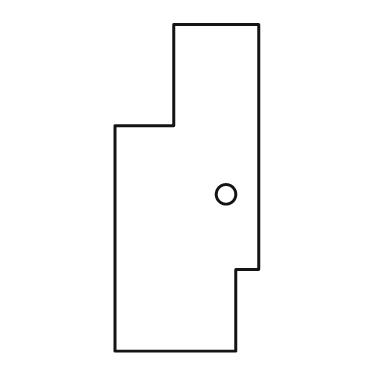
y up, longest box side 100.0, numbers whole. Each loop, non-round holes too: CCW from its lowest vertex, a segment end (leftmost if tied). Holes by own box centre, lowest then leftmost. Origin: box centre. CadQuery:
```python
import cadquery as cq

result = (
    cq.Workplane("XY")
    .moveTo(-22.0, -50.0)
    .lineTo(15.0, -50.0)
    .lineTo(15.0, -25.0)
    .lineTo(22.0, -25.0)
    .lineTo(22.0, 50.0)
    .lineTo(-4.0, 50.0)
    .lineTo(-4.0, 19.0)
    .lineTo(-22.0, 19.0)
    .close()
    .moveTo(12.0, -2.0)
    .circle(3.0)
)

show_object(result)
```